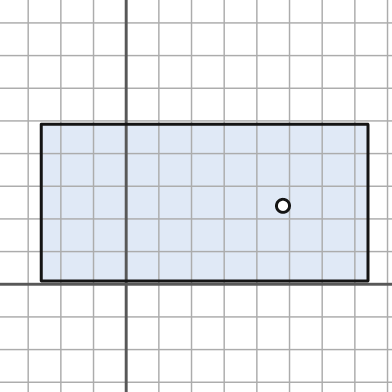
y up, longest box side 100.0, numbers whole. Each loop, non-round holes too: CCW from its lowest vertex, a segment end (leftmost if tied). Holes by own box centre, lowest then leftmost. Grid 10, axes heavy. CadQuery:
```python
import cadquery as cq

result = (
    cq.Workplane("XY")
    .moveTo(-26.0, 1.0)
    .lineTo(74.0, 1.0)
    .lineTo(74.0, 49.0)
    .lineTo(-26.0, 49.0)
    .close()
    .moveTo(48.0, 24.0)
    .circle(2.0)
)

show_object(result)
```